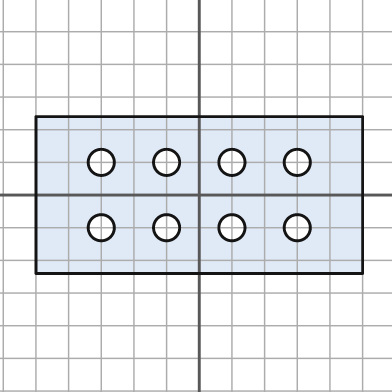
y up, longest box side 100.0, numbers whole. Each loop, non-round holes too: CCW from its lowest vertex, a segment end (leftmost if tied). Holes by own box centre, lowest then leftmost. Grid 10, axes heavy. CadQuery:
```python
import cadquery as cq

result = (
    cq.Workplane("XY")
    .moveTo(-50.0, -24.0)
    .lineTo(50.0, -24.0)
    .lineTo(50.0, 24.0)
    .lineTo(-50.0, 24.0)
    .close()
    .moveTo(-30.0, -10.0)
    .circle(4.0)
    .moveTo(-10.0, -10.0)
    .circle(4.0)
    .moveTo(10.0, -10.0)
    .circle(4.0)
    .moveTo(30.0, -10.0)
    .circle(4.0)
    .moveTo(-30.0, 10.0)
    .circle(4.0)
    .moveTo(-10.0, 10.0)
    .circle(4.0)
    .moveTo(10.0, 10.0)
    .circle(4.0)
    .moveTo(30.0, 10.0)
    .circle(4.0)
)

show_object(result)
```